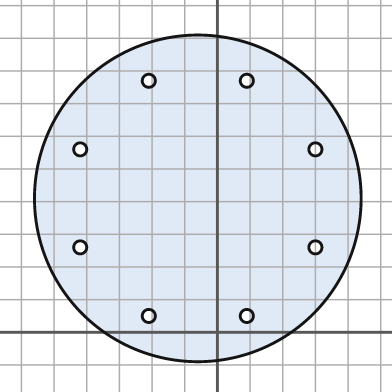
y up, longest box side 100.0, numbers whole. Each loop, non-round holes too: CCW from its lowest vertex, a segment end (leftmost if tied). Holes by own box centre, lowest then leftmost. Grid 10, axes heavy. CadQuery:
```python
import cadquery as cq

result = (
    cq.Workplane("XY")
    .moveTo(-6.0, 41.0)
    .circle(50.0)
    .moveTo(-21.0, 5.0)
    .circle(2.0)
    .moveTo(9.0, 5.0)
    .circle(2.0)
    .moveTo(-42.0, 26.0)
    .circle(2.0)
    .moveTo(30.0, 26.0)
    .circle(2.0)
    .moveTo(-42.0, 56.0)
    .circle(2.0)
    .moveTo(30.0, 56.0)
    .circle(2.0)
    .moveTo(-21.0, 77.0)
    .circle(2.0)
    .moveTo(9.0, 77.0)
    .circle(2.0)
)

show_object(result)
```